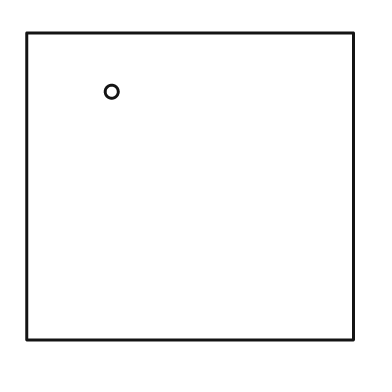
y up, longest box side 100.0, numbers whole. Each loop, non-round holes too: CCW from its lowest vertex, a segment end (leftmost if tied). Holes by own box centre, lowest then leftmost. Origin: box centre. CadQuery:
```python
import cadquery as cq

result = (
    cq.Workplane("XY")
    .moveTo(-50.0, -47.0)
    .lineTo(50.0, -47.0)
    .lineTo(50.0, 47.0)
    .lineTo(-50.0, 47.0)
    .close()
    .moveTo(-24.0, 29.0)
    .circle(2.0)
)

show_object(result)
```